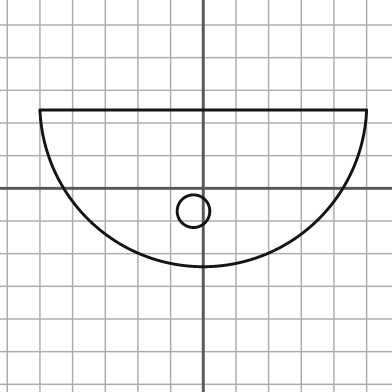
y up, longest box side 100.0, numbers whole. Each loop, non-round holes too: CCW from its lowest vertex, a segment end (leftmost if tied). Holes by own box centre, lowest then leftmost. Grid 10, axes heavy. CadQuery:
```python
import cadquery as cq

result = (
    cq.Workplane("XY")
    .moveTo(-50.0, 24.0)
    .threePointArc((0.0, -24.0), (50.0, 24.0))
    .close()
    .moveTo(-3.0, -7.0)
    .circle(5.0)
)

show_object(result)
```